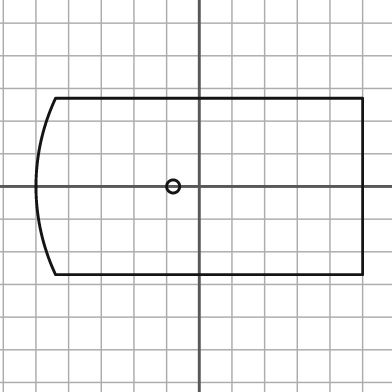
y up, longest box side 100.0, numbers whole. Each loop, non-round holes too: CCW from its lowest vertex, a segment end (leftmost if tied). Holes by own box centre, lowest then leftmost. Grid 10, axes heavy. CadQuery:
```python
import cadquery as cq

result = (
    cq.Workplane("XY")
    .moveTo(-44.0, -27.0)
    .lineTo(50.0, -27.0)
    .lineTo(50.0, 27.0)
    .lineTo(-44.0, 27.0)
    .threePointArc((-50.0, 0.0), (-44.0, -27.0))
    .close()
    .moveTo(-8.0, 0.0)
    .circle(2.0)
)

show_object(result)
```